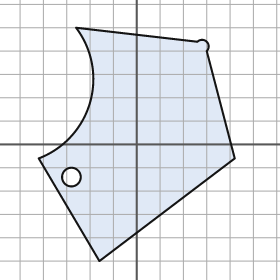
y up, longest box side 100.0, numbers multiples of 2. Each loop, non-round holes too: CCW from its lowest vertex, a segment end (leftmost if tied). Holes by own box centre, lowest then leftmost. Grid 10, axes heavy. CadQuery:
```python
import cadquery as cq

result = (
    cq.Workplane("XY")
    .moveTo(-16.0, -50.0)
    .lineTo(42.0, -6.0)
    .lineTo(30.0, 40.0)
    .threePointArc((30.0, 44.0), (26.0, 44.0))
    .lineTo(-26.0, 50.0)
    .threePointArc((-20.0, 18.0), (-42.0, -6.0))
    .close()
    .moveTo(-28.0, -14.0)
    .circle(4.0)
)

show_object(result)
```